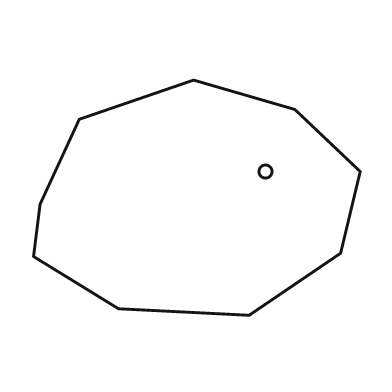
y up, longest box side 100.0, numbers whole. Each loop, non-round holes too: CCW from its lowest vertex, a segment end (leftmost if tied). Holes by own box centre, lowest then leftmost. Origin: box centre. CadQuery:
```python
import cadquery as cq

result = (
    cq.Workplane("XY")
    .moveTo(16.0, -36.0)
    .lineTo(44.0, -17.0)
    .lineTo(50.0, 8.0)
    .lineTo(30.0, 27.0)
    .lineTo(-1.0, 36.0)
    .lineTo(-36.0, 24.0)
    .lineTo(-48.0, -2.0)
    .lineTo(-50.0, -18.0)
    .lineTo(-24.0, -34.0)
    .close()
    .moveTo(21.0, 8.0)
    .circle(2.0)
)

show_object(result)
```